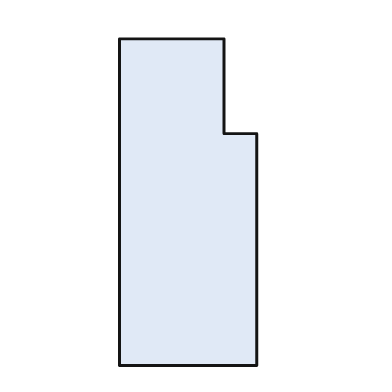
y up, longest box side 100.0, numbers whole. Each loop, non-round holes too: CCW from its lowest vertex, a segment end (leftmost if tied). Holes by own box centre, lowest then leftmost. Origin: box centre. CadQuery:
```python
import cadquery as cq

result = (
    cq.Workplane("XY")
    .moveTo(-21.0, -50.0)
    .lineTo(21.0, -50.0)
    .lineTo(21.0, 21.0)
    .lineTo(11.0, 21.0)
    .lineTo(11.0, 50.0)
    .lineTo(-21.0, 50.0)
    .close()
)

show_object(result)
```